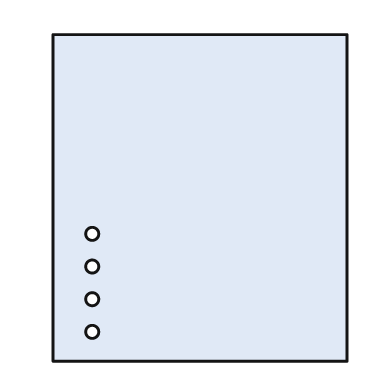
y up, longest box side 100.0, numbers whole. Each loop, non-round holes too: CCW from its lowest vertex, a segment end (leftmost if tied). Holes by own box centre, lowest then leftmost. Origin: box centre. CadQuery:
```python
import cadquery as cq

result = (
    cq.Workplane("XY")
    .moveTo(-45.0, -50.0)
    .lineTo(45.0, -50.0)
    .lineTo(45.0, 50.0)
    .lineTo(-45.0, 50.0)
    .close()
    .moveTo(-33.0, -41.0)
    .circle(2.0)
    .moveTo(-33.0, -31.0)
    .circle(2.0)
    .moveTo(-33.0, -21.0)
    .circle(2.0)
    .moveTo(-33.0, -11.0)
    .circle(2.0)
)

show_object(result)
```